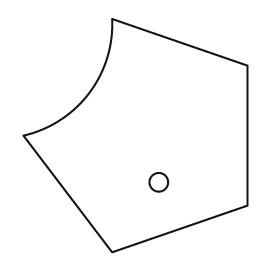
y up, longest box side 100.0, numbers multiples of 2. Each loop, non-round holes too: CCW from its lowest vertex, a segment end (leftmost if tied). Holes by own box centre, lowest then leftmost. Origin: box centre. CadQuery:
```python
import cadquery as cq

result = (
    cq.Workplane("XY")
    .moveTo(-10.0, -50.0)
    .lineTo(48.0, -30.0)
    .lineTo(48.0, 30.0)
    .lineTo(-10.0, 50.0)
    .threePointArc((-20.0, 18.0), (-48.0, 0.0))
    .close()
    .moveTo(10.0, -20.0)
    .circle(4.0)
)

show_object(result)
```